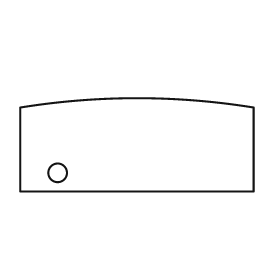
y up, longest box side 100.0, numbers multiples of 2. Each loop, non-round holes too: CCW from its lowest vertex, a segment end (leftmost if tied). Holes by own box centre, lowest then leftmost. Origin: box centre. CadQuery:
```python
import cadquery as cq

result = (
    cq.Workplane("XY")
    .moveTo(-50.0, -20.0)
    .lineTo(50.0, -20.0)
    .lineTo(50.0, 16.0)
    .threePointArc((0.0, 20.0), (-50.0, 16.0))
    .close()
    .moveTo(-34.0, -12.0)
    .circle(4.0)
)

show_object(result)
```